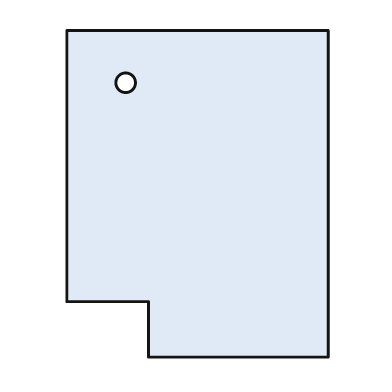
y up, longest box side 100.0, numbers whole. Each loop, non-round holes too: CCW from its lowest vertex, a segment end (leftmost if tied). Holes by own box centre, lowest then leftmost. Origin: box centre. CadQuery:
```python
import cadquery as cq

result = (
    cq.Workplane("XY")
    .moveTo(-15.0, -50.0)
    .lineTo(40.0, -50.0)
    .lineTo(40.0, 50.0)
    .lineTo(-40.0, 50.0)
    .lineTo(-40.0, -33.0)
    .lineTo(-15.0, -33.0)
    .close()
    .moveTo(-22.0, 34.0)
    .circle(3.0)
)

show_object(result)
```